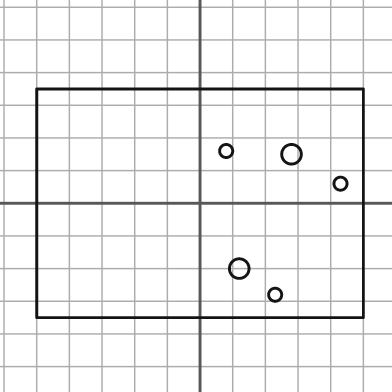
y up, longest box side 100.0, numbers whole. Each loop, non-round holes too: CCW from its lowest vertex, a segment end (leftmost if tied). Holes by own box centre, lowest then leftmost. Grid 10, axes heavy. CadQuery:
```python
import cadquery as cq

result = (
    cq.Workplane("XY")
    .moveTo(-50.0, -35.0)
    .lineTo(50.0, -35.0)
    .lineTo(50.0, 35.0)
    .lineTo(-50.0, 35.0)
    .close()
    .moveTo(23.0, -28.0)
    .circle(2.0)
    .moveTo(12.0, -20.0)
    .circle(3.0)
    .moveTo(43.0, 6.0)
    .circle(2.0)
    .moveTo(28.0, 15.0)
    .circle(3.0)
    .moveTo(8.0, 16.0)
    .circle(2.0)
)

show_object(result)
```